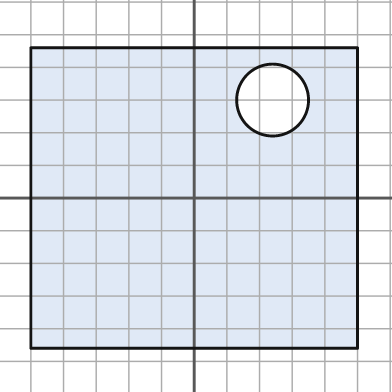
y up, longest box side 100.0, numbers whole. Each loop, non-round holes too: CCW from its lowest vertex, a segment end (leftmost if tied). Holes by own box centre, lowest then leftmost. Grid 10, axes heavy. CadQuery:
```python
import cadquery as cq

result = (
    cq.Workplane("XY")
    .moveTo(-50.0, -46.0)
    .lineTo(50.0, -46.0)
    .lineTo(50.0, 46.0)
    .lineTo(-50.0, 46.0)
    .close()
    .moveTo(24.0, 30.0)
    .circle(11.0)
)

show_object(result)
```